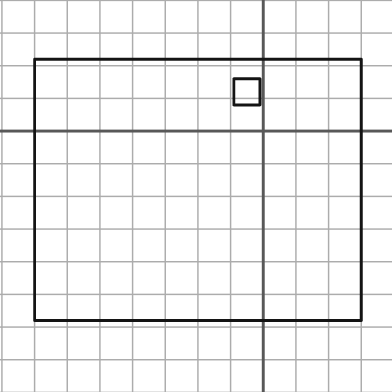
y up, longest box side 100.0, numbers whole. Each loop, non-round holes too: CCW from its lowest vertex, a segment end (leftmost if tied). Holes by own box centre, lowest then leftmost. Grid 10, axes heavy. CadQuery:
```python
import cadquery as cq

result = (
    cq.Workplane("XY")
    .moveTo(-70.0, -58.0)
    .lineTo(30.0, -58.0)
    .lineTo(30.0, 22.0)
    .lineTo(-70.0, 22.0)
    .close()
    .moveTo(-9.0, 8.0)
    .lineTo(-1.0, 8.0)
    .lineTo(-1.0, 16.0)
    .lineTo(-9.0, 16.0)
    .close()
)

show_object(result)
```